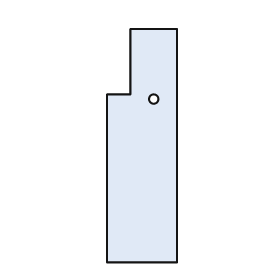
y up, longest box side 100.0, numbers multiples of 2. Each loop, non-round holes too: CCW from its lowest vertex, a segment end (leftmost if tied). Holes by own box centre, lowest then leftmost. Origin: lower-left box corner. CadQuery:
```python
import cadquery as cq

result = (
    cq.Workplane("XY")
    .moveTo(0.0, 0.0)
    .lineTo(30.0, 0.0)
    .lineTo(30.0, 100.0)
    .lineTo(10.0, 100.0)
    .lineTo(10.0, 72.0)
    .lineTo(0.0, 72.0)
    .close()
    .moveTo(20.0, 70.0)
    .circle(2.0)
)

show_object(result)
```